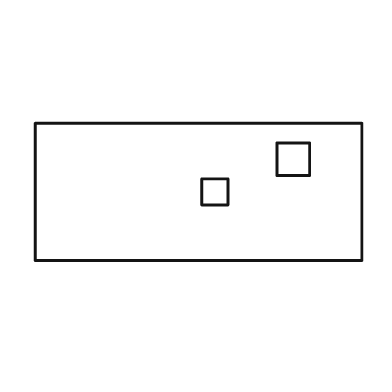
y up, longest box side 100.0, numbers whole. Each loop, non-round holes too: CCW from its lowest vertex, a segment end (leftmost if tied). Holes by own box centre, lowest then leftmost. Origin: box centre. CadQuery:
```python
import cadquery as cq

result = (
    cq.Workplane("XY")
    .moveTo(-50.0, -21.0)
    .lineTo(50.0, -21.0)
    .lineTo(50.0, 21.0)
    .lineTo(-50.0, 21.0)
    .close()
    .moveTo(1.0, -4.0)
    .lineTo(9.0, -4.0)
    .lineTo(9.0, 4.0)
    .lineTo(1.0, 4.0)
    .close()
    .moveTo(24.0, 5.0)
    .lineTo(34.0, 5.0)
    .lineTo(34.0, 15.0)
    .lineTo(24.0, 15.0)
    .close()
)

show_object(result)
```